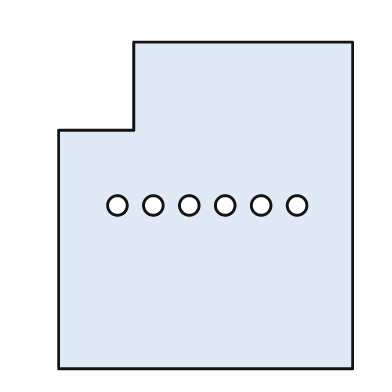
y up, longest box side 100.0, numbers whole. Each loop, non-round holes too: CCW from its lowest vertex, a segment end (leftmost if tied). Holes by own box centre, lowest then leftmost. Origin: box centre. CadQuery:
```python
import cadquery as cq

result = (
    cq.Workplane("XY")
    .moveTo(-45.0, -50.0)
    .lineTo(45.0, -50.0)
    .lineTo(45.0, 50.0)
    .lineTo(-22.0, 50.0)
    .lineTo(-22.0, 23.0)
    .lineTo(-45.0, 23.0)
    .close()
    .moveTo(-27.0, 0.0)
    .circle(3.0)
    .moveTo(-16.0, 0.0)
    .circle(3.0)
    .moveTo(-5.0, 0.0)
    .circle(3.0)
    .moveTo(6.0, 0.0)
    .circle(3.0)
    .moveTo(17.0, 0.0)
    .circle(3.0)
    .moveTo(28.0, 0.0)
    .circle(3.0)
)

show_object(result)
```